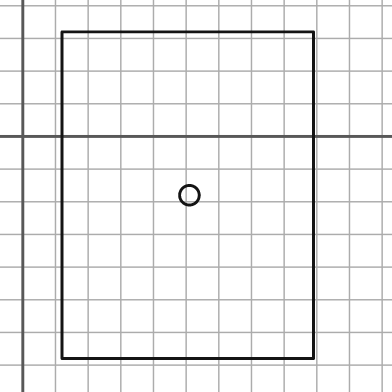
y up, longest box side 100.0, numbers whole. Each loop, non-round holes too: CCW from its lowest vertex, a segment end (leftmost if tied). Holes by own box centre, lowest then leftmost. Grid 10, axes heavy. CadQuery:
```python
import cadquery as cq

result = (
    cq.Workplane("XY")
    .moveTo(12.0, -68.0)
    .lineTo(89.0, -68.0)
    .lineTo(89.0, 32.0)
    .lineTo(12.0, 32.0)
    .close()
    .moveTo(51.0, -18.0)
    .circle(3.0)
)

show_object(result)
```